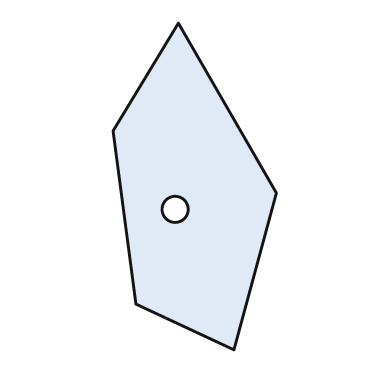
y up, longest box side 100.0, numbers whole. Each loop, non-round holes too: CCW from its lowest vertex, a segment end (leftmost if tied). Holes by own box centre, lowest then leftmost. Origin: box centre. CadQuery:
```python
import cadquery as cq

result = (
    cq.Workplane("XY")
    .moveTo(12.0, -50.0)
    .lineTo(25.0, -2.0)
    .lineTo(-5.0, 50.0)
    .lineTo(-25.0, 17.0)
    .lineTo(-18.0, -36.0)
    .close()
    .moveTo(-6.0, -7.0)
    .circle(4.0)
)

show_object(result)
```